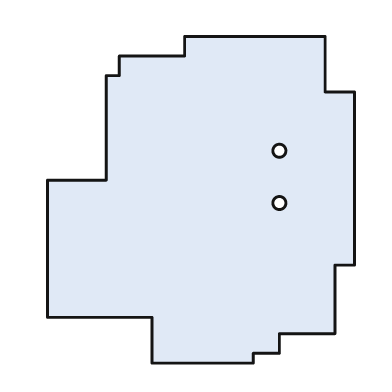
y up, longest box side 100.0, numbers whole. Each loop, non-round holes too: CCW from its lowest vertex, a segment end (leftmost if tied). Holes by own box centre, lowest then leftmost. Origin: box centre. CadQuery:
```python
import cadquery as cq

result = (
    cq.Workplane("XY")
    .moveTo(-15.0, -50.0)
    .lineTo(16.0, -50.0)
    .lineTo(16.0, -47.0)
    .lineTo(24.0, -47.0)
    .lineTo(24.0, -41.0)
    .lineTo(41.0, -41.0)
    .lineTo(41.0, -20.0)
    .lineTo(47.0, -20.0)
    .lineTo(47.0, 33.0)
    .lineTo(38.0, 33.0)
    .lineTo(38.0, 50.0)
    .lineTo(-5.0, 50.0)
    .lineTo(-5.0, 44.0)
    .lineTo(-25.0, 44.0)
    .lineTo(-25.0, 38.0)
    .lineTo(-29.0, 38.0)
    .lineTo(-29.0, 6.0)
    .lineTo(-47.0, 6.0)
    .lineTo(-47.0, -36.0)
    .lineTo(-15.0, -36.0)
    .close()
    .moveTo(24.0, -1.0)
    .circle(2.0)
    .moveTo(24.0, 15.0)
    .circle(2.0)
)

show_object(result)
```